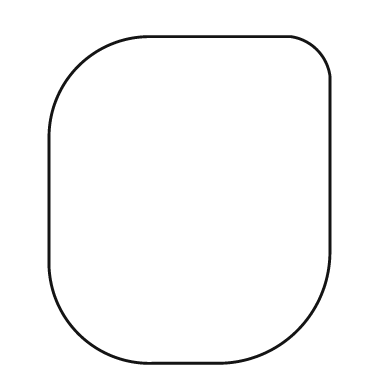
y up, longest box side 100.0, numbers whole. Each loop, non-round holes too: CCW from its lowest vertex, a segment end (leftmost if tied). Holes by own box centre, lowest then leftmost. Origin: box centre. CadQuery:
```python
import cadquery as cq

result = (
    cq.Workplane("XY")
    .moveTo(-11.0, -50.0)
    .lineTo(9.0, -50.0)
    .threePointArc((33.0, -40.0), (43.0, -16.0))
    .lineTo(43.0, 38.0)
    .threePointArc((39.0, 46.0), (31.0, 50.0))
    .lineTo(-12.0, 50.0)
    .threePointArc((-34.0, 41.0), (-43.0, 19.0))
    .lineTo(-43.0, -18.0)
    .threePointArc((-34.0, -41.0), (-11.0, -50.0))
    .close()
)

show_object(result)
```